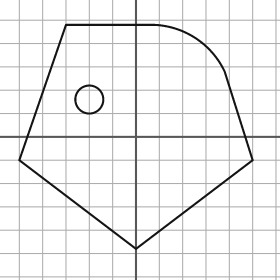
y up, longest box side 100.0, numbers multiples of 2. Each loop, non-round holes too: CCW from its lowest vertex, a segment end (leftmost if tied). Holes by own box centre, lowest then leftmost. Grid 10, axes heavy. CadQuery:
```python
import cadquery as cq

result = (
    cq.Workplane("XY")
    .moveTo(0.0, -48.0)
    .lineTo(50.0, -10.0)
    .lineTo(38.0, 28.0)
    .threePointArc((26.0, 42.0), (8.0, 48.0))
    .lineTo(-30.0, 48.0)
    .lineTo(-50.0, -10.0)
    .close()
    .moveTo(-20.0, 16.0)
    .circle(6.0)
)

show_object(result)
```